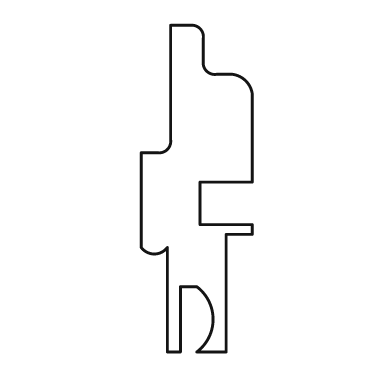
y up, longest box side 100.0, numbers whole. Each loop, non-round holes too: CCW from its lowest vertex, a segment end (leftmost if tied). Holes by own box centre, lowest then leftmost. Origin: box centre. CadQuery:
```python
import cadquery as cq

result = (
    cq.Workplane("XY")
    .moveTo(-9.0, -50.0)
    .lineTo(-5.0, -50.0)
    .lineTo(-5.0, -30.0)
    .lineTo(0.0, -30.0)
    .threePointArc((5.0, -40.0), (0.0, -50.0))
    .lineTo(9.0, -50.0)
    .lineTo(9.0, -14.0)
    .lineTo(17.0, -14.0)
    .lineTo(17.0, -11.0)
    .lineTo(1.0, -11.0)
    .lineTo(1.0, 2.0)
    .lineTo(17.0, 2.0)
    .lineTo(17.0, 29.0)
    .threePointArc((15.0, 33.0), (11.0, 35.0))
    .lineTo(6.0, 35.0)
    .threePointArc((3.0, 36.0), (2.0, 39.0))
    .lineTo(2.0, 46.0)
    .threePointArc((1.0, 49.0), (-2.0, 50.0))
    .lineTo(-8.0, 50.0)
    .lineTo(-8.0, 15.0)
    .threePointArc((-9.0, 12.0), (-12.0, 11.0))
    .lineTo(-17.0, 11.0)
    .lineTo(-17.0, -18.0)
    .threePointArc((-13.0, -20.0), (-9.0, -18.0))
    .close()
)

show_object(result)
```